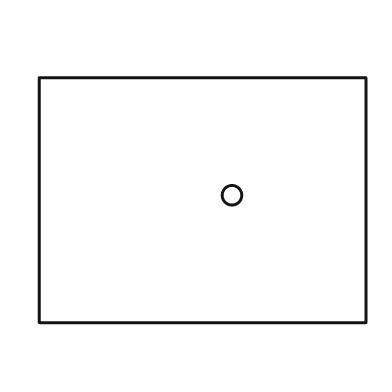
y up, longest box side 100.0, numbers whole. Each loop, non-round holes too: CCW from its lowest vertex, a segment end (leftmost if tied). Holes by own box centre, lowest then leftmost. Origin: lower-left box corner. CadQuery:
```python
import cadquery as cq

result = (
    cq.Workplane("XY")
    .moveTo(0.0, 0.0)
    .lineTo(100.0, 0.0)
    .lineTo(100.0, 75.0)
    .lineTo(0.0, 75.0)
    .close()
    .moveTo(59.0, 39.0)
    .circle(3.0)
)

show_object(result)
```